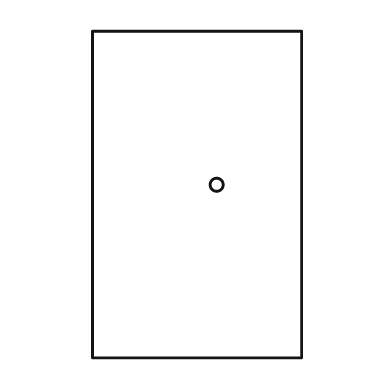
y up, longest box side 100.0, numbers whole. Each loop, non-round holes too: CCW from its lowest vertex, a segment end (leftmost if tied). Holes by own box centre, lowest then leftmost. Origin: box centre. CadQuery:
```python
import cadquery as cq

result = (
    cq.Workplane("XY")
    .moveTo(-32.0, -50.0)
    .lineTo(32.0, -50.0)
    .lineTo(32.0, 50.0)
    .lineTo(-32.0, 50.0)
    .close()
    .moveTo(6.0, 3.0)
    .circle(2.0)
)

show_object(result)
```